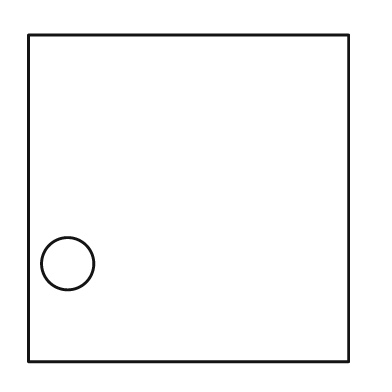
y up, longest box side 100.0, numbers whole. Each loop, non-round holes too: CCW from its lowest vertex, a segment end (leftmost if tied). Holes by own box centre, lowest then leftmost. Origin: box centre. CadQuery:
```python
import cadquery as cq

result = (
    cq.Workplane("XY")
    .moveTo(-49.0, -50.0)
    .lineTo(49.0, -50.0)
    .lineTo(49.0, 50.0)
    .lineTo(-49.0, 50.0)
    .close()
    .moveTo(-37.0, -20.0)
    .circle(8.0)
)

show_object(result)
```